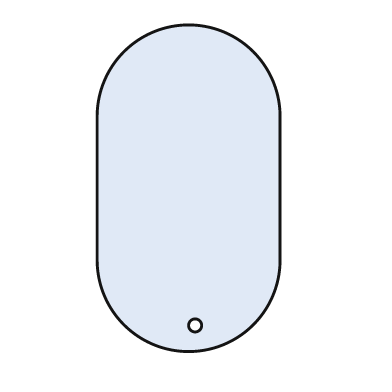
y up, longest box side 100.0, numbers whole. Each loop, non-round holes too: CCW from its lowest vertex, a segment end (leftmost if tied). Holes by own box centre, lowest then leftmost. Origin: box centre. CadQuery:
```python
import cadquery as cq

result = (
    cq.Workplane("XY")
    .moveTo(-28.0, -22.0)
    .threePointArc((0.0, -50.0), (28.0, -22.0))
    .lineTo(28.0, 22.0)
    .threePointArc((0.0, 50.0), (-28.0, 22.0))
    .close()
    .moveTo(2.0, -42.0)
    .circle(2.0)
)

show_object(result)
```